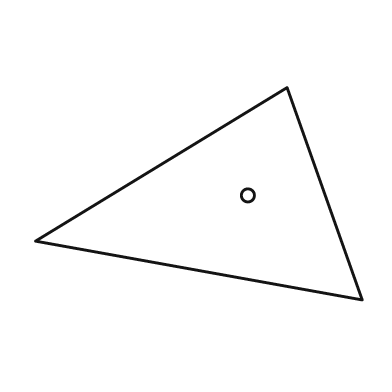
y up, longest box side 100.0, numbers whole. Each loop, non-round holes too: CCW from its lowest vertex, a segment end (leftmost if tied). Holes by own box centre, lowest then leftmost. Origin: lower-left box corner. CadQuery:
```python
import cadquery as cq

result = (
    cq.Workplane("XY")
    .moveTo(100.0, 0.0)
    .lineTo(77.0, 65.0)
    .lineTo(0.0, 18.0)
    .close()
    .moveTo(65.0, 32.0)
    .circle(2.0)
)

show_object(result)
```